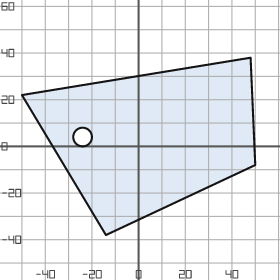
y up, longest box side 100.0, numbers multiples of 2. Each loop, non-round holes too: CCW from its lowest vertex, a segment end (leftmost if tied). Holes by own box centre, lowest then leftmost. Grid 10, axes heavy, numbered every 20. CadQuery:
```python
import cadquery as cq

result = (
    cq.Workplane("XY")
    .moveTo(-14.0, -38.0)
    .lineTo(50.0, -8.0)
    .lineTo(48.0, 38.0)
    .lineTo(-50.0, 22.0)
    .close()
    .moveTo(-24.0, 4.0)
    .circle(4.0)
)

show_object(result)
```